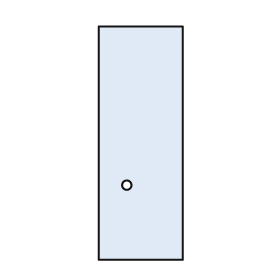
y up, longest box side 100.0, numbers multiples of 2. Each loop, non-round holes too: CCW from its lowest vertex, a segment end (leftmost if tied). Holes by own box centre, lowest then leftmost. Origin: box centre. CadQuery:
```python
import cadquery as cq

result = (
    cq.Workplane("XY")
    .moveTo(-18.0, -50.0)
    .lineTo(18.0, -50.0)
    .lineTo(18.0, 50.0)
    .lineTo(-18.0, 50.0)
    .close()
    .moveTo(-6.0, -18.0)
    .circle(2.0)
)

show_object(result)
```